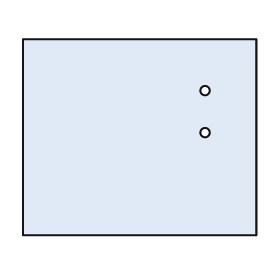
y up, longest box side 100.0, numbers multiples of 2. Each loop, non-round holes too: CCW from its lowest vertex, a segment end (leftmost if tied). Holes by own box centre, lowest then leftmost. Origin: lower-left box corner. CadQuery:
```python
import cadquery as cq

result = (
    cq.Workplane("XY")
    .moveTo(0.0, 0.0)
    .lineTo(100.0, 0.0)
    .lineTo(100.0, 84.0)
    .lineTo(0.0, 84.0)
    .close()
    .moveTo(78.0, 44.0)
    .circle(2.0)
    .moveTo(78.0, 62.0)
    .circle(2.0)
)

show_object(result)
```